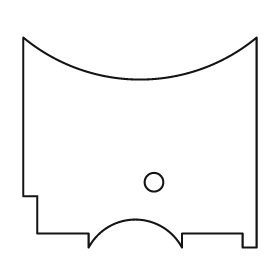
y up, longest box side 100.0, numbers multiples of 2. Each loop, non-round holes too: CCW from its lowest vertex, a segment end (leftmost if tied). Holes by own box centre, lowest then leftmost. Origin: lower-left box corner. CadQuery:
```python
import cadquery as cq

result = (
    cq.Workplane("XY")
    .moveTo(28.0, 0.0)
    .threePointArc((48.0, 12.0), (68.0, 0.0))
    .lineTo(68.0, 6.0)
    .lineTo(94.0, 6.0)
    .lineTo(94.0, 0.0)
    .lineTo(100.0, 0.0)
    .lineTo(100.0, 90.0)
    .threePointArc((50.0, 72.0), (0.0, 90.0))
    .lineTo(0.0, 22.0)
    .lineTo(6.0, 22.0)
    .lineTo(6.0, 6.0)
    .lineTo(28.0, 6.0)
    .close()
    .moveTo(56.0, 28.0)
    .circle(4.0)
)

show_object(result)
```